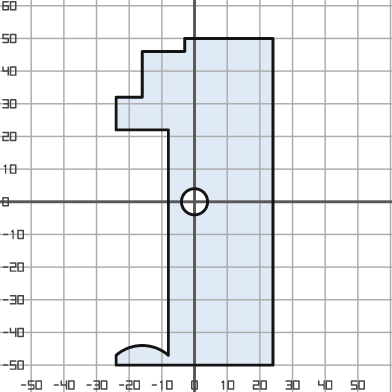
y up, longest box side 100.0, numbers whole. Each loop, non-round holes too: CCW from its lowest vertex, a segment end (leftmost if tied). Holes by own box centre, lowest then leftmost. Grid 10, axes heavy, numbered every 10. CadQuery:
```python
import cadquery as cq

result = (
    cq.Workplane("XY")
    .moveTo(-24.0, -50.0)
    .lineTo(24.0, -50.0)
    .lineTo(24.0, 50.0)
    .lineTo(-3.0, 50.0)
    .lineTo(-3.0, 46.0)
    .lineTo(-16.0, 46.0)
    .lineTo(-16.0, 32.0)
    .lineTo(-24.0, 32.0)
    .lineTo(-24.0, 22.0)
    .lineTo(-8.0, 22.0)
    .lineTo(-8.0, -47.0)
    .threePointArc((-16.0, -44.0), (-24.0, -47.0))
    .close()
    .moveTo(0.0, 0.0)
    .circle(4.0)
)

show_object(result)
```